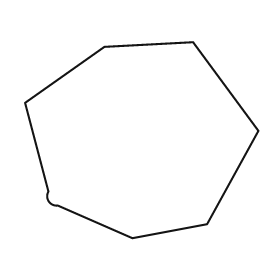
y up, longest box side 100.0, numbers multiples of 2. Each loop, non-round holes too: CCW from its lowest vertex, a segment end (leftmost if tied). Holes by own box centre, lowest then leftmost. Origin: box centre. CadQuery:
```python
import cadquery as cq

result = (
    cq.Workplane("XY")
    .moveTo(-4.0, -42.0)
    .lineTo(28.0, -36.0)
    .lineTo(50.0, 4.0)
    .lineTo(22.0, 42.0)
    .lineTo(-16.0, 40.0)
    .lineTo(-50.0, 16.0)
    .lineTo(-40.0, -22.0)
    .threePointArc((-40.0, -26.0), (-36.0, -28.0))
    .close()
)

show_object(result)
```